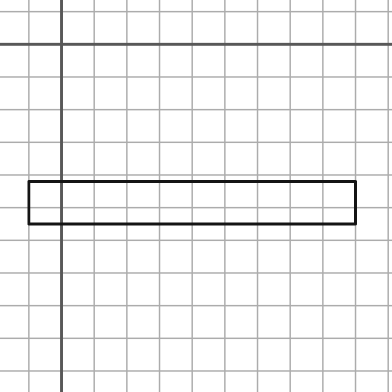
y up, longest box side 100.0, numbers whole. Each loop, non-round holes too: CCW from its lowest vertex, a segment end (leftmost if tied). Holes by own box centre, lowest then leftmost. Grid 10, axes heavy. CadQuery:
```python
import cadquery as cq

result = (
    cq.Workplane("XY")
    .moveTo(-10.0, -55.0)
    .lineTo(90.0, -55.0)
    .lineTo(90.0, -42.0)
    .lineTo(-10.0, -42.0)
    .close()
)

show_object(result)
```